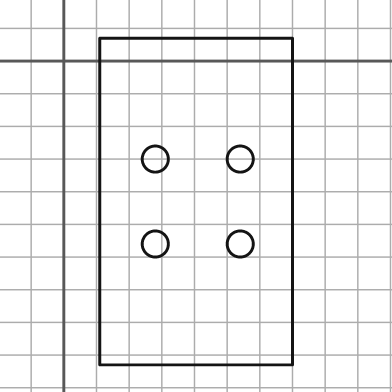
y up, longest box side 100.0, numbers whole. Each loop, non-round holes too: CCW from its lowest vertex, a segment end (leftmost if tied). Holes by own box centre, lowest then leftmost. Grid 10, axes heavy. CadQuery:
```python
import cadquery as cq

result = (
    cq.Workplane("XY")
    .moveTo(11.0, -93.0)
    .lineTo(70.0, -93.0)
    .lineTo(70.0, 7.0)
    .lineTo(11.0, 7.0)
    .close()
    .moveTo(28.0, -56.0)
    .circle(4.0)
    .moveTo(54.0, -56.0)
    .circle(4.0)
    .moveTo(28.0, -30.0)
    .circle(4.0)
    .moveTo(54.0, -30.0)
    .circle(4.0)
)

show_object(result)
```